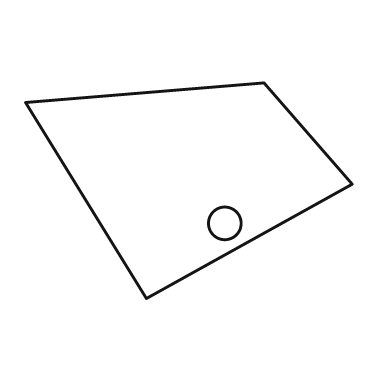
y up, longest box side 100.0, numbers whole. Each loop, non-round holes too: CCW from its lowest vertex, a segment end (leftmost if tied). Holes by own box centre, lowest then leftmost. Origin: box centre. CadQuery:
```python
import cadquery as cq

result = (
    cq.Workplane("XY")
    .moveTo(-13.0, -33.0)
    .lineTo(50.0, 2.0)
    .lineTo(23.0, 33.0)
    .lineTo(-50.0, 27.0)
    .close()
    .moveTo(11.0, -10.0)
    .circle(5.0)
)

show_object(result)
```